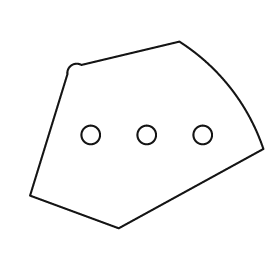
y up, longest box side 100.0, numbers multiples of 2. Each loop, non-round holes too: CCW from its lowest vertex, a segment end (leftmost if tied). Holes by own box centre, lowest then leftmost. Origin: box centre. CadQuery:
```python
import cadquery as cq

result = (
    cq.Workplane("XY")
    .moveTo(-12.0, -40.0)
    .lineTo(50.0, -6.0)
    .threePointArc((36.0, 20.0), (14.0, 40.0))
    .lineTo(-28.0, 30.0)
    .threePointArc((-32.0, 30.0), (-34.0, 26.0))
    .lineTo(-50.0, -26.0)
    .close()
    .moveTo(-24.0, 0.0)
    .circle(4.0)
    .moveTo(0.0, 0.0)
    .circle(4.0)
    .moveTo(24.0, 0.0)
    .circle(4.0)
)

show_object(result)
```